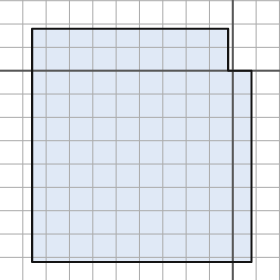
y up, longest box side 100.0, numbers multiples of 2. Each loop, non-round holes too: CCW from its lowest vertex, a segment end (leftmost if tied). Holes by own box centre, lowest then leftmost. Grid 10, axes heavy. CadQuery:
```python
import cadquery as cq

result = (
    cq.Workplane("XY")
    .moveTo(-86.0, -82.0)
    .lineTo(8.0, -82.0)
    .lineTo(8.0, 0.0)
    .lineTo(-2.0, 0.0)
    .lineTo(-2.0, 18.0)
    .lineTo(-86.0, 18.0)
    .close()
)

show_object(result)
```